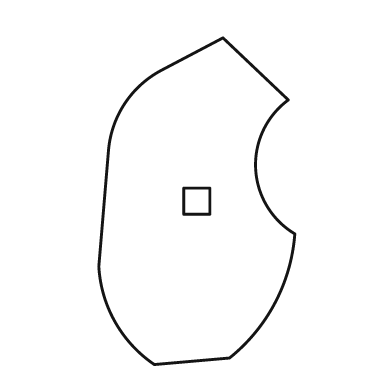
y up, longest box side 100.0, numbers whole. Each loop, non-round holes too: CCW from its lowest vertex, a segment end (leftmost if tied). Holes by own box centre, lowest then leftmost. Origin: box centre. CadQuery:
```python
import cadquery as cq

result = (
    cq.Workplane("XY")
    .moveTo(-13.0, -50.0)
    .lineTo(10.0, -48.0)
    .threePointArc((24.0, -31.0), (30.0, -10.0))
    .threePointArc((18.0, 10.0), (28.0, 31.0))
    .lineTo(8.0, 50.0)
    .lineTo(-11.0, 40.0)
    .threePointArc((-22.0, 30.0), (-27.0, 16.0))
    .lineTo(-30.0, -20.0)
    .threePointArc((-25.0, -37.0), (-13.0, -50.0))
    .close()
    .moveTo(-4.0, -4.0)
    .lineTo(4.0, -4.0)
    .lineTo(4.0, 4.0)
    .lineTo(-4.0, 4.0)
    .close()
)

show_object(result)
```